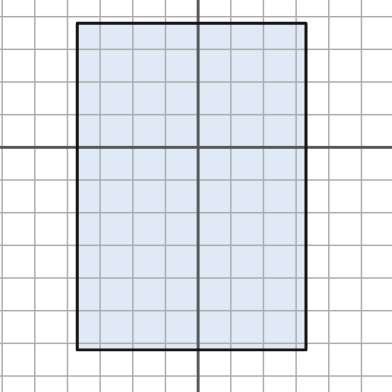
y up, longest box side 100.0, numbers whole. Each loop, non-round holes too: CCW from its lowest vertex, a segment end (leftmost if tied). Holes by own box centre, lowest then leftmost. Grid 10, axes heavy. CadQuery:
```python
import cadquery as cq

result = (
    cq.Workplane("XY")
    .moveTo(-37.0, -62.0)
    .lineTo(33.0, -62.0)
    .lineTo(33.0, 38.0)
    .lineTo(-37.0, 38.0)
    .close()
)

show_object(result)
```